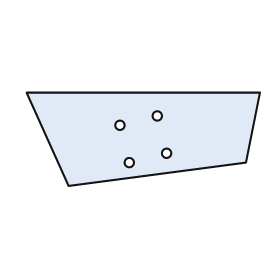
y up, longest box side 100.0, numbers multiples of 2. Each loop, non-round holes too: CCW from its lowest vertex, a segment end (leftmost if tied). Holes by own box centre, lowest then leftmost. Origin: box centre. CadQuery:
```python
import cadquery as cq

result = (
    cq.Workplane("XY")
    .moveTo(-32.0, -20.0)
    .lineTo(44.0, -10.0)
    .lineTo(50.0, 20.0)
    .lineTo(-50.0, 20.0)
    .close()
    .moveTo(-6.0, -10.0)
    .circle(2.0)
    .moveTo(10.0, -6.0)
    .circle(2.0)
    .moveTo(-10.0, 6.0)
    .circle(2.0)
    .moveTo(6.0, 10.0)
    .circle(2.0)
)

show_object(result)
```